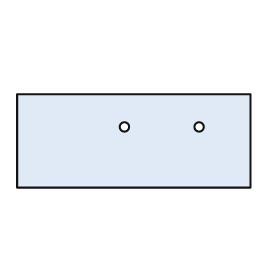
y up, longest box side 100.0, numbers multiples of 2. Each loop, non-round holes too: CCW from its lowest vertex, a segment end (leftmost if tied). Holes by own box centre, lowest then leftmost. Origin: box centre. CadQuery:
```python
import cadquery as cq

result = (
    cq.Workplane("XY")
    .moveTo(-50.0, -20.0)
    .lineTo(50.0, -20.0)
    .lineTo(50.0, 20.0)
    .lineTo(-50.0, 20.0)
    .close()
    .moveTo(-4.0, 6.0)
    .circle(2.0)
    .moveTo(28.0, 6.0)
    .circle(2.0)
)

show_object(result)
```